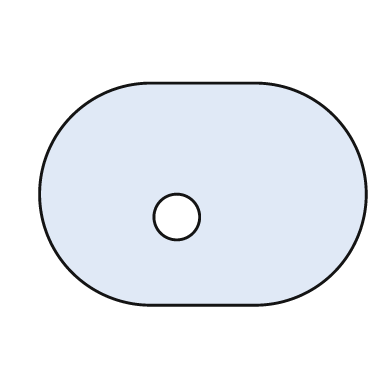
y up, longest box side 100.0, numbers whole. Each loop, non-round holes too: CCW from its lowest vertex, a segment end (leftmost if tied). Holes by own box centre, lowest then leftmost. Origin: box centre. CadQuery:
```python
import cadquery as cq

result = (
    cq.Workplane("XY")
    .moveTo(-16.0, -34.0)
    .lineTo(16.0, -34.0)
    .threePointArc((50.0, 0.0), (16.0, 34.0))
    .lineTo(-16.0, 34.0)
    .threePointArc((-50.0, 0.0), (-16.0, -34.0))
    .close()
    .moveTo(-8.0, -7.0)
    .circle(7.0)
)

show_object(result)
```